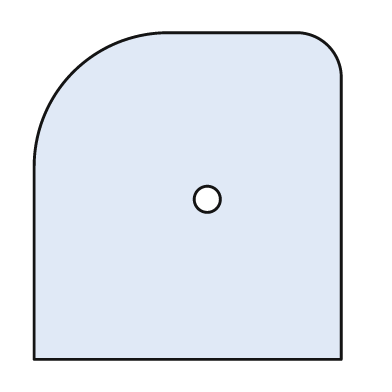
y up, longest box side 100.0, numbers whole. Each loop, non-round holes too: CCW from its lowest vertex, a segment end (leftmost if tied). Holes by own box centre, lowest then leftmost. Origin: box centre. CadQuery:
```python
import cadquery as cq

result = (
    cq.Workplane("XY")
    .moveTo(-47.0, -50.0)
    .lineTo(47.0, -50.0)
    .lineTo(47.0, 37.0)
    .threePointArc((43.0, 46.0), (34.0, 50.0))
    .lineTo(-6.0, 50.0)
    .threePointArc((-35.0, 38.0), (-47.0, 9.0))
    .close()
    .moveTo(6.0, -1.0)
    .circle(4.0)
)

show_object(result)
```